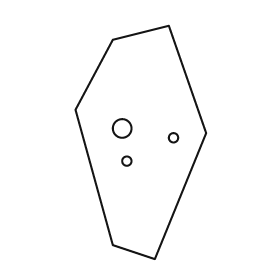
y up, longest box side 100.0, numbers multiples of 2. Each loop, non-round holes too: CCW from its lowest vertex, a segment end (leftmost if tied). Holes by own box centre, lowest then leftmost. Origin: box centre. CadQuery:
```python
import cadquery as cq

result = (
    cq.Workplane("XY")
    .moveTo(6.0, -50.0)
    .lineTo(28.0, 4.0)
    .lineTo(12.0, 50.0)
    .lineTo(-12.0, 44.0)
    .lineTo(-28.0, 14.0)
    .lineTo(-12.0, -44.0)
    .close()
    .moveTo(-6.0, -8.0)
    .circle(2.0)
    .moveTo(14.0, 2.0)
    .circle(2.0)
    .moveTo(-8.0, 6.0)
    .circle(4.0)
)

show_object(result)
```